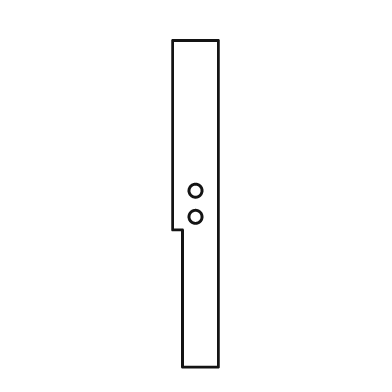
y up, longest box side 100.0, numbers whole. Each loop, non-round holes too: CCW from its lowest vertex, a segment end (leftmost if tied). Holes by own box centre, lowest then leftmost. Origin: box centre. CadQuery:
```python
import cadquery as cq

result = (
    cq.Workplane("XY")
    .moveTo(-4.0, -50.0)
    .lineTo(7.0, -50.0)
    .lineTo(7.0, 50.0)
    .lineTo(-7.0, 50.0)
    .lineTo(-7.0, -8.0)
    .lineTo(-4.0, -8.0)
    .close()
    .moveTo(0.0, -4.0)
    .circle(2.0)
    .moveTo(0.0, 4.0)
    .circle(2.0)
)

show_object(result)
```